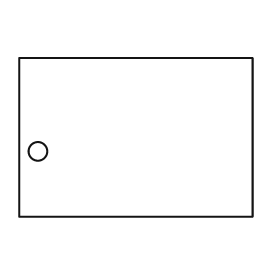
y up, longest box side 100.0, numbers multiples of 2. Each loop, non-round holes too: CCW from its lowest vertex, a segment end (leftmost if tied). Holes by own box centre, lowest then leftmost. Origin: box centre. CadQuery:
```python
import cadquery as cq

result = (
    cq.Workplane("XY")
    .moveTo(-50.0, -34.0)
    .lineTo(50.0, -34.0)
    .lineTo(50.0, 34.0)
    .lineTo(-50.0, 34.0)
    .close()
    .moveTo(-42.0, -6.0)
    .circle(4.0)
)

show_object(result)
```